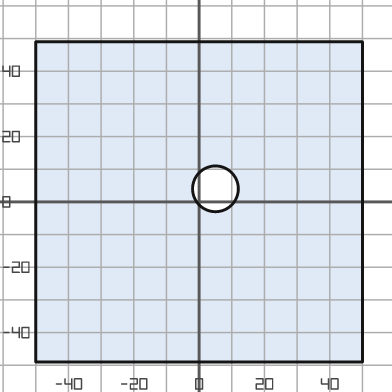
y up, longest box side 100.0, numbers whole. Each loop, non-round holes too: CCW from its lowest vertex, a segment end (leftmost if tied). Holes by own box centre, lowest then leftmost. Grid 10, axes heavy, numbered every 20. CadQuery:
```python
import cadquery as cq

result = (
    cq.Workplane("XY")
    .moveTo(-50.0, -49.0)
    .lineTo(50.0, -49.0)
    .lineTo(50.0, 49.0)
    .lineTo(-50.0, 49.0)
    .close()
    .moveTo(5.0, 4.0)
    .circle(7.0)
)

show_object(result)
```